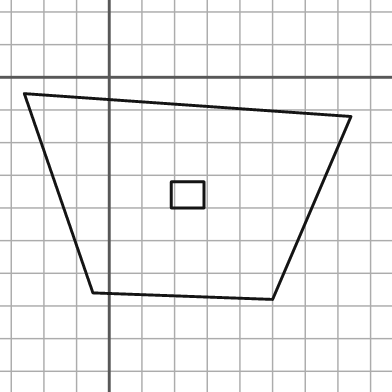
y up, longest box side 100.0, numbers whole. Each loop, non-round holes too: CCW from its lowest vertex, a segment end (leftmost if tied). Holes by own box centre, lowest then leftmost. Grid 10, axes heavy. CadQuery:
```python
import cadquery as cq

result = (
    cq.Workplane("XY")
    .moveTo(50.0, -68.0)
    .lineTo(74.0, -12.0)
    .lineTo(-26.0, -5.0)
    .lineTo(-5.0, -66.0)
    .close()
    .moveTo(19.0, -40.0)
    .lineTo(29.0, -40.0)
    .lineTo(29.0, -32.0)
    .lineTo(19.0, -32.0)
    .close()
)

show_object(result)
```